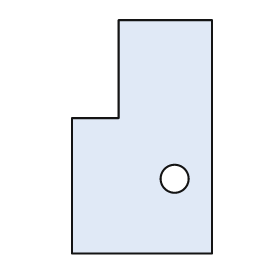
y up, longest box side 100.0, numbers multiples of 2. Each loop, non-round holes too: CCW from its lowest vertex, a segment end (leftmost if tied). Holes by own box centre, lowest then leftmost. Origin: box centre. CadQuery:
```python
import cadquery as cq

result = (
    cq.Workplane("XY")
    .moveTo(-30.0, -50.0)
    .lineTo(30.0, -50.0)
    .lineTo(30.0, 50.0)
    .lineTo(-10.0, 50.0)
    .lineTo(-10.0, 8.0)
    .lineTo(-30.0, 8.0)
    .close()
    .moveTo(14.0, -18.0)
    .circle(6.0)
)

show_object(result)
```